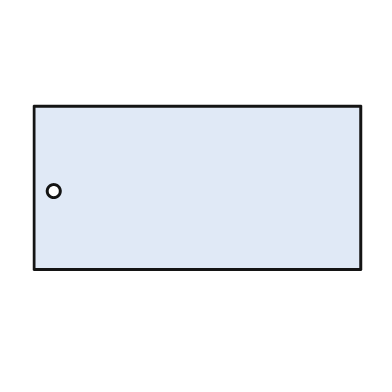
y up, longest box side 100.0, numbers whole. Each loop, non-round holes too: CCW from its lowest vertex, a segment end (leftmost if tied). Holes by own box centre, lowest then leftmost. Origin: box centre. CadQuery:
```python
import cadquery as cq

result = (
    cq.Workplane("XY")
    .moveTo(-50.0, -25.0)
    .lineTo(50.0, -25.0)
    .lineTo(50.0, 25.0)
    .lineTo(-50.0, 25.0)
    .close()
    .moveTo(-44.0, -1.0)
    .circle(2.0)
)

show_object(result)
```